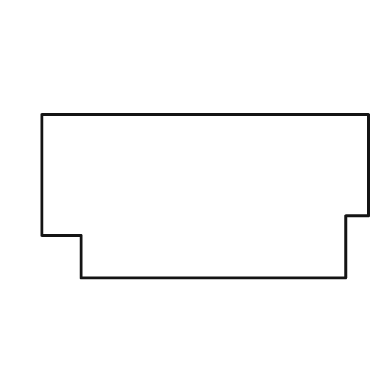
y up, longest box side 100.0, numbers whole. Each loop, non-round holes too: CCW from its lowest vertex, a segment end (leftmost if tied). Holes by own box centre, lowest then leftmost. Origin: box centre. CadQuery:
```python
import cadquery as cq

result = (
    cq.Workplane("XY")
    .moveTo(-38.0, -25.0)
    .lineTo(43.0, -25.0)
    .lineTo(43.0, -6.0)
    .lineTo(50.0, -6.0)
    .lineTo(50.0, 25.0)
    .lineTo(-50.0, 25.0)
    .lineTo(-50.0, -12.0)
    .lineTo(-38.0, -12.0)
    .close()
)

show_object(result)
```